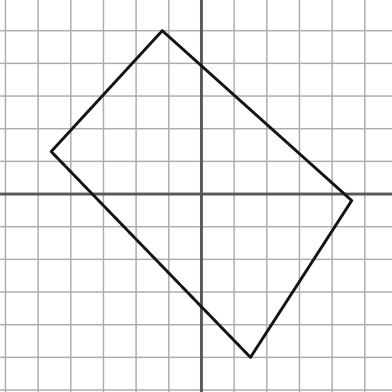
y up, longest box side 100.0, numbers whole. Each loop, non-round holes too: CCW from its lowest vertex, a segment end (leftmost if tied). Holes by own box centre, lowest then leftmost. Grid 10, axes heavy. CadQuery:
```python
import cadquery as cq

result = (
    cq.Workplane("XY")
    .moveTo(15.0, -50.0)
    .lineTo(46.0, -2.0)
    .lineTo(-12.0, 50.0)
    .lineTo(-46.0, 13.0)
    .close()
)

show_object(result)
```